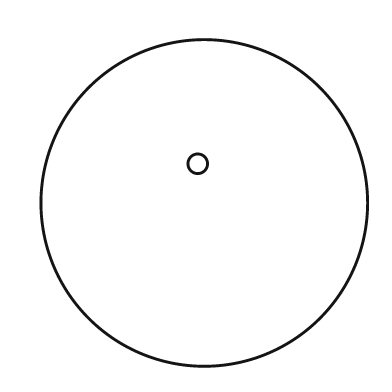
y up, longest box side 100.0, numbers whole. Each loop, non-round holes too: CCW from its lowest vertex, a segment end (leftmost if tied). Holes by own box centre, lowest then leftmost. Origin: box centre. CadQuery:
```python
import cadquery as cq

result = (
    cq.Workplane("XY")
    .moveTo(0.0, 0.0)
    .circle(50.0)
    .moveTo(-2.0, 12.0)
    .circle(3.0)
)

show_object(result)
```